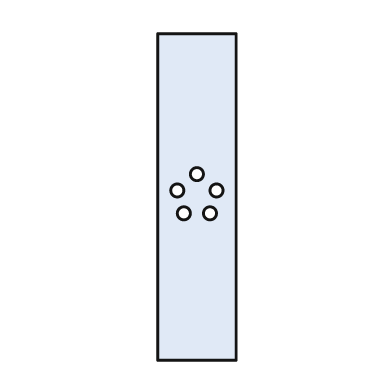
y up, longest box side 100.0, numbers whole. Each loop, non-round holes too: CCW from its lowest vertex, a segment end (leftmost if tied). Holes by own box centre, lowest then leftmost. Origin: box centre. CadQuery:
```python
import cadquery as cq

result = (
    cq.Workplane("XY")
    .moveTo(-12.0, -50.0)
    .lineTo(12.0, -50.0)
    .lineTo(12.0, 50.0)
    .lineTo(-12.0, 50.0)
    .close()
    .moveTo(-4.0, -5.0)
    .circle(2.0)
    .moveTo(4.0, -5.0)
    .circle(2.0)
    .moveTo(-6.0, 2.0)
    .circle(2.0)
    .moveTo(6.0, 2.0)
    .circle(2.0)
    .moveTo(0.0, 7.0)
    .circle(2.0)
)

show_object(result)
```